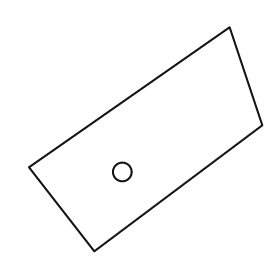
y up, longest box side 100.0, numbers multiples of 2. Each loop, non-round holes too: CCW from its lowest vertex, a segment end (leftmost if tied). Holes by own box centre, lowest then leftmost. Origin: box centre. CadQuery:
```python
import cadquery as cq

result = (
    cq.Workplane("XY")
    .moveTo(-22.0, -48.0)
    .lineTo(50.0, 6.0)
    .lineTo(36.0, 48.0)
    .lineTo(-50.0, -12.0)
    .close()
    .moveTo(-10.0, -14.0)
    .circle(4.0)
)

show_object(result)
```